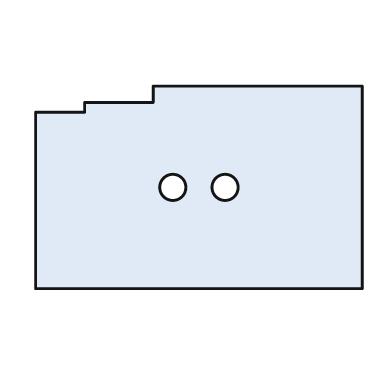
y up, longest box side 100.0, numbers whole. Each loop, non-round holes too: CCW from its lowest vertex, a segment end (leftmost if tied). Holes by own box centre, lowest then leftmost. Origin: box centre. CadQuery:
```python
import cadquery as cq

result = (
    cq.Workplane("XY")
    .moveTo(-50.0, -31.0)
    .lineTo(50.0, -31.0)
    .lineTo(50.0, 31.0)
    .lineTo(-14.0, 31.0)
    .lineTo(-14.0, 26.0)
    .lineTo(-35.0, 26.0)
    .lineTo(-35.0, 23.0)
    .lineTo(-50.0, 23.0)
    .close()
    .moveTo(-8.0, 0.0)
    .circle(4.0)
    .moveTo(8.0, 0.0)
    .circle(4.0)
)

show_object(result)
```